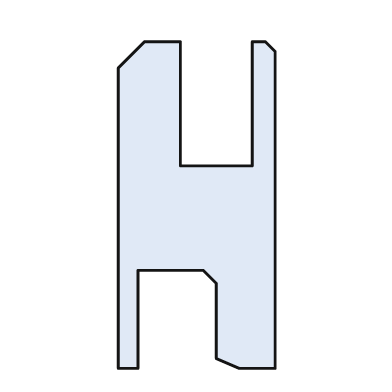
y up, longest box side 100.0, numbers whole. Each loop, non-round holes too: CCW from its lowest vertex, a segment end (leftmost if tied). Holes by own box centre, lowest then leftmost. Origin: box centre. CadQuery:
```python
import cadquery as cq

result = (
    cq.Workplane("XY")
    .moveTo(-24.0, -50.0)
    .lineTo(-18.0, -50.0)
    .lineTo(-18.0, -20.0)
    .lineTo(2.0, -20.0)
    .lineTo(6.0, -24.0)
    .lineTo(6.0, -47.0)
    .lineTo(13.0, -50.0)
    .lineTo(24.0, -50.0)
    .lineTo(24.0, 47.0)
    .lineTo(21.0, 50.0)
    .lineTo(17.0, 50.0)
    .lineTo(17.0, 12.0)
    .lineTo(-5.0, 12.0)
    .lineTo(-5.0, 50.0)
    .lineTo(-16.0, 50.0)
    .lineTo(-24.0, 42.0)
    .close()
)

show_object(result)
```